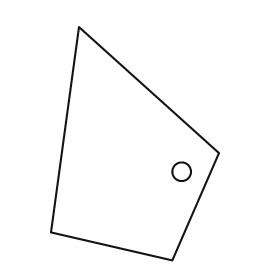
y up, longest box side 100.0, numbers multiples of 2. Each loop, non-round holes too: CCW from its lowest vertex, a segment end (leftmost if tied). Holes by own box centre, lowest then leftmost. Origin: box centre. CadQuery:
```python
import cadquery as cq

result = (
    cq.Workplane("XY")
    .moveTo(16.0, -50.0)
    .lineTo(36.0, -4.0)
    .lineTo(-24.0, 50.0)
    .lineTo(-36.0, -38.0)
    .close()
    .moveTo(20.0, -12.0)
    .circle(4.0)
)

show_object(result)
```